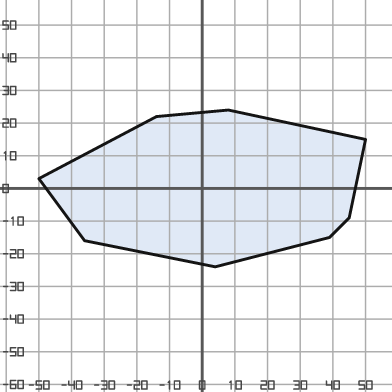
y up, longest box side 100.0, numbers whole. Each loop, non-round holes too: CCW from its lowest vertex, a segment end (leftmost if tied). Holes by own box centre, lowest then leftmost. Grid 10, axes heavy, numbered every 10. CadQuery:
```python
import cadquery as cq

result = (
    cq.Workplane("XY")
    .moveTo(4.0, -24.0)
    .lineTo(39.0, -15.0)
    .lineTo(45.0, -9.0)
    .lineTo(50.0, 15.0)
    .lineTo(8.0, 24.0)
    .lineTo(-14.0, 22.0)
    .lineTo(-50.0, 3.0)
    .lineTo(-36.0, -16.0)
    .close()
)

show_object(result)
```